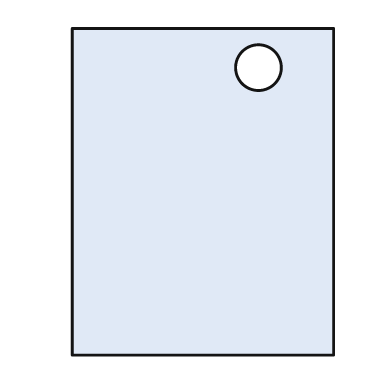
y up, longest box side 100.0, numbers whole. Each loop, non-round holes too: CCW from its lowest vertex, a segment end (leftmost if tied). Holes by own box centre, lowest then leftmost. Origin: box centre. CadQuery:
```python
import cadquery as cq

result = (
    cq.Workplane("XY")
    .moveTo(-40.0, -50.0)
    .lineTo(40.0, -50.0)
    .lineTo(40.0, 50.0)
    .lineTo(-40.0, 50.0)
    .close()
    .moveTo(17.0, 38.0)
    .circle(7.0)
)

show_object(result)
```